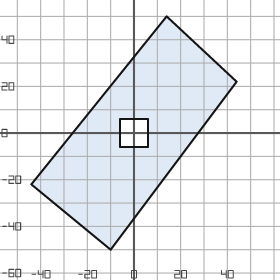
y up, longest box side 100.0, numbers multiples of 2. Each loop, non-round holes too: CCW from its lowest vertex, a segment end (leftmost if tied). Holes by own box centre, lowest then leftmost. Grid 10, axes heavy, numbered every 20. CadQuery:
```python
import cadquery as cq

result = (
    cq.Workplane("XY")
    .moveTo(-10.0, -50.0)
    .lineTo(44.0, 22.0)
    .lineTo(14.0, 50.0)
    .lineTo(-44.0, -22.0)
    .close()
    .moveTo(-6.0, -6.0)
    .lineTo(6.0, -6.0)
    .lineTo(6.0, 6.0)
    .lineTo(-6.0, 6.0)
    .close()
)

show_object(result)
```